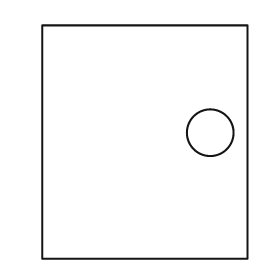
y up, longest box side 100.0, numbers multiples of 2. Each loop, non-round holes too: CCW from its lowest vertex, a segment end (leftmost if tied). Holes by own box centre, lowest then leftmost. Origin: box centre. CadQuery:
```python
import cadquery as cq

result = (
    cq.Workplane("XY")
    .moveTo(-44.0, -50.0)
    .lineTo(44.0, -50.0)
    .lineTo(44.0, 50.0)
    .lineTo(-44.0, 50.0)
    .close()
    .moveTo(28.0, 4.0)
    .circle(10.0)
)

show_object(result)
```